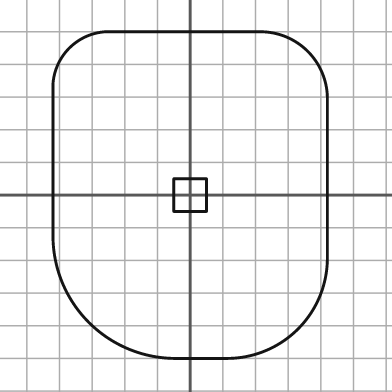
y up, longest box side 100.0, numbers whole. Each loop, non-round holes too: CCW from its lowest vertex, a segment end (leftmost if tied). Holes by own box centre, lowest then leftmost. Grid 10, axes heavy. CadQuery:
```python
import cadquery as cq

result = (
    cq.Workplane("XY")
    .moveTo(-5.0, -50.0)
    .lineTo(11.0, -50.0)
    .threePointArc((33.0, -41.0), (42.0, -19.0))
    .lineTo(42.0, 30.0)
    .threePointArc((36.0, 44.0), (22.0, 50.0))
    .lineTo(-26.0, 50.0)
    .threePointArc((-37.0, 45.0), (-42.0, 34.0))
    .lineTo(-42.0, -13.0)
    .threePointArc((-31.0, -39.0), (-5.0, -50.0))
    .close()
    .moveTo(-5.0, -5.0)
    .lineTo(5.0, -5.0)
    .lineTo(5.0, 5.0)
    .lineTo(-5.0, 5.0)
    .close()
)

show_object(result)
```